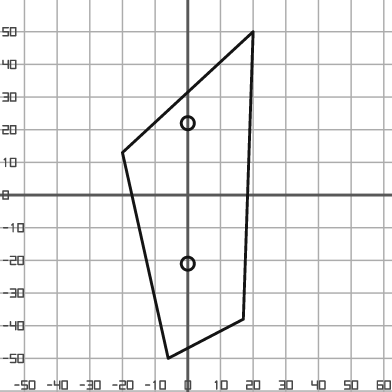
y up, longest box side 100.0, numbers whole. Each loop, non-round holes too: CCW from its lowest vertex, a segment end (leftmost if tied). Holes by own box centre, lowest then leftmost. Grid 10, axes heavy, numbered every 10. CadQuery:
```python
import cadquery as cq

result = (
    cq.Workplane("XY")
    .moveTo(-6.0, -50.0)
    .lineTo(17.0, -38.0)
    .lineTo(20.0, 50.0)
    .lineTo(-20.0, 13.0)
    .close()
    .moveTo(0.0, -21.0)
    .circle(2.0)
    .moveTo(0.0, 22.0)
    .circle(2.0)
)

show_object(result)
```